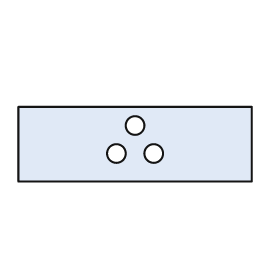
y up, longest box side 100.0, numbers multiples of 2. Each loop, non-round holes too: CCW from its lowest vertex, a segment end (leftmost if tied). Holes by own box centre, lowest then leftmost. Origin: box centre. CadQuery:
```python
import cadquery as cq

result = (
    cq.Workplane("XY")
    .moveTo(-50.0, -16.0)
    .lineTo(50.0, -16.0)
    .lineTo(50.0, 16.0)
    .lineTo(-50.0, 16.0)
    .close()
    .moveTo(-8.0, -4.0)
    .circle(4.0)
    .moveTo(8.0, -4.0)
    .circle(4.0)
    .moveTo(0.0, 8.0)
    .circle(4.0)
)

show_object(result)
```